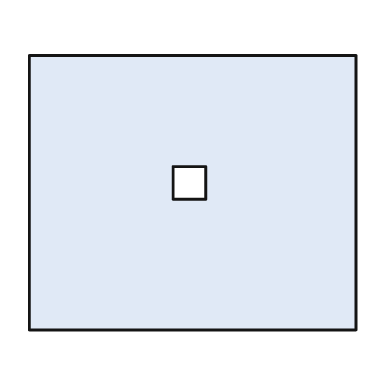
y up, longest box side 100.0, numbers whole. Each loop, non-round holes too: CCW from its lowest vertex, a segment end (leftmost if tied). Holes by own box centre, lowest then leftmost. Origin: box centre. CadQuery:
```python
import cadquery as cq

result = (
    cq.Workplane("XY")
    .moveTo(-50.0, -42.0)
    .lineTo(50.0, -42.0)
    .lineTo(50.0, 42.0)
    .lineTo(-50.0, 42.0)
    .close()
    .moveTo(-6.0, -2.0)
    .lineTo(4.0, -2.0)
    .lineTo(4.0, 8.0)
    .lineTo(-6.0, 8.0)
    .close()
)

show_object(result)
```